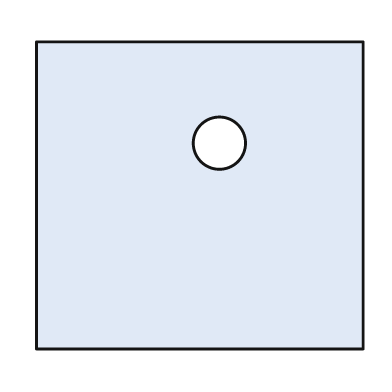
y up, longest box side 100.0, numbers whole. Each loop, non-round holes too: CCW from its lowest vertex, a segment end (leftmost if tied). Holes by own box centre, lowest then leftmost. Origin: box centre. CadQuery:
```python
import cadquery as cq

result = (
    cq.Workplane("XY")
    .moveTo(-50.0, -47.0)
    .lineTo(50.0, -47.0)
    .lineTo(50.0, 47.0)
    .lineTo(-50.0, 47.0)
    .close()
    .moveTo(6.0, 16.0)
    .circle(8.0)
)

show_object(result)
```